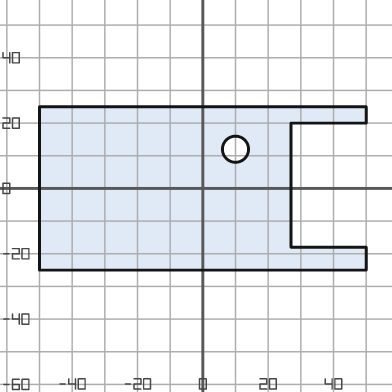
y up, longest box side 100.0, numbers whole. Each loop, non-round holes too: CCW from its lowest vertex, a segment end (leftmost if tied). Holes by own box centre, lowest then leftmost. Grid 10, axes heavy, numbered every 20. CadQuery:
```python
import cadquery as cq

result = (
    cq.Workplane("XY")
    .moveTo(-50.0, -25.0)
    .lineTo(50.0, -25.0)
    .lineTo(50.0, -18.0)
    .lineTo(27.0, -18.0)
    .lineTo(27.0, 20.0)
    .lineTo(50.0, 20.0)
    .lineTo(50.0, 25.0)
    .lineTo(-50.0, 25.0)
    .close()
    .moveTo(10.0, 12.0)
    .circle(4.0)
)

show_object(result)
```